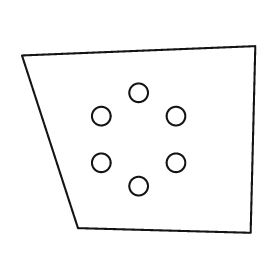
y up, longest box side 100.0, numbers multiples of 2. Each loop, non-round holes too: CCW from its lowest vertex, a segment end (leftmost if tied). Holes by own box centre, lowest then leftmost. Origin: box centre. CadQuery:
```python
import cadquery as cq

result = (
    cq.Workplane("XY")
    .moveTo(48.0, -40.0)
    .lineTo(50.0, 40.0)
    .lineTo(-50.0, 36.0)
    .lineTo(-26.0, -38.0)
    .close()
    .moveTo(0.0, -20.0)
    .circle(4.0)
    .moveTo(-16.0, -10.0)
    .circle(4.0)
    .moveTo(16.0, -10.0)
    .circle(4.0)
    .moveTo(-16.0, 10.0)
    .circle(4.0)
    .moveTo(16.0, 10.0)
    .circle(4.0)
    .moveTo(0.0, 20.0)
    .circle(4.0)
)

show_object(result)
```